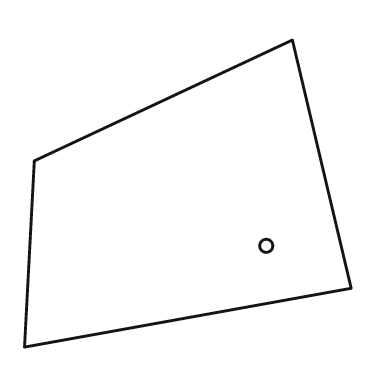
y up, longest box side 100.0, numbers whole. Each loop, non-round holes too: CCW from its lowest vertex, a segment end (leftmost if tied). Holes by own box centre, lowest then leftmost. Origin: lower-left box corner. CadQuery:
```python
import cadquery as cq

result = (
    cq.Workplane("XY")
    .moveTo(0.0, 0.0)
    .lineTo(100.0, 18.0)
    .lineTo(82.0, 94.0)
    .lineTo(3.0, 57.0)
    .close()
    .moveTo(74.0, 31.0)
    .circle(2.0)
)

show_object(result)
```